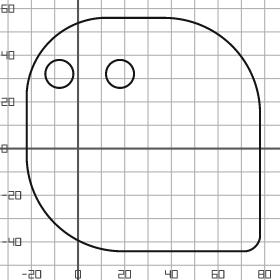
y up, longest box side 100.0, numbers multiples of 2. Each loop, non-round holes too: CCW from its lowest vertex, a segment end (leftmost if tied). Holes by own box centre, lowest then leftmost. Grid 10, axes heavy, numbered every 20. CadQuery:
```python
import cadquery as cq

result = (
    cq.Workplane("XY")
    .moveTo(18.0, -44.0)
    .lineTo(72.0, -44.0)
    .threePointArc((76.0, -42.0), (78.0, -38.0))
    .lineTo(78.0, 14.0)
    .threePointArc((66.0, 44.0), (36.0, 56.0))
    .lineTo(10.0, 56.0)
    .threePointArc((-12.0, 46.0), (-22.0, 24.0))
    .lineTo(-22.0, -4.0)
    .threePointArc((-10.0, -32.0), (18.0, -44.0))
    .close()
    .moveTo(-8.0, 32.0)
    .circle(6.0)
    .moveTo(18.0, 32.0)
    .circle(6.0)
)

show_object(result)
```